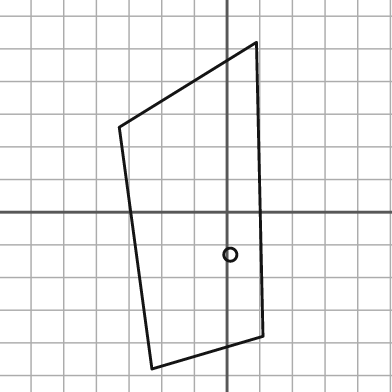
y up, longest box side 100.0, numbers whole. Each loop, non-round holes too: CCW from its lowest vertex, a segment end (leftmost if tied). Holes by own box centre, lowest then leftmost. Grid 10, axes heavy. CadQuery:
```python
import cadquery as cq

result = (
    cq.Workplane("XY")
    .moveTo(-23.0, -48.0)
    .lineTo(11.0, -38.0)
    .lineTo(9.0, 52.0)
    .lineTo(-33.0, 26.0)
    .close()
    .moveTo(1.0, -13.0)
    .circle(2.0)
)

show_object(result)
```